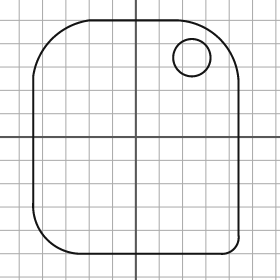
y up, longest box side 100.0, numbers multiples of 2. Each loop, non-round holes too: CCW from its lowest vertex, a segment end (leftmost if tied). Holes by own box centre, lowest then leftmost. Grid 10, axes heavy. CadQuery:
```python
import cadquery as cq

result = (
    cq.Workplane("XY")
    .moveTo(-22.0, -50.0)
    .lineTo(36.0, -50.0)
    .threePointArc((42.0, -48.0), (44.0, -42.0))
    .lineTo(44.0, 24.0)
    .threePointArc((36.0, 42.0), (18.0, 50.0))
    .lineTo(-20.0, 50.0)
    .threePointArc((-36.0, 42.0), (-44.0, 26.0))
    .lineTo(-44.0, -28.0)
    .threePointArc((-38.0, -44.0), (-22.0, -50.0))
    .close()
    .moveTo(24.0, 34.0)
    .circle(8.0)
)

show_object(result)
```